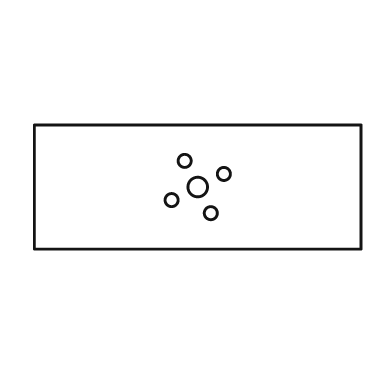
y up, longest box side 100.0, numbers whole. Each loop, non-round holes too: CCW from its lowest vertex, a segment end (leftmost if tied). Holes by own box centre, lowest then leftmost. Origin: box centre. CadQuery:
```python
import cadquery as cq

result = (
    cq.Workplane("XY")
    .moveTo(-50.0, -19.0)
    .lineTo(50.0, -19.0)
    .lineTo(50.0, 19.0)
    .lineTo(-50.0, 19.0)
    .close()
    .moveTo(4.0, -8.0)
    .circle(2.0)
    .moveTo(-8.0, -4.0)
    .circle(2.0)
    .moveTo(0.0, 0.0)
    .circle(3.0)
    .moveTo(8.0, 4.0)
    .circle(2.0)
    .moveTo(-4.0, 8.0)
    .circle(2.0)
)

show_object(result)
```